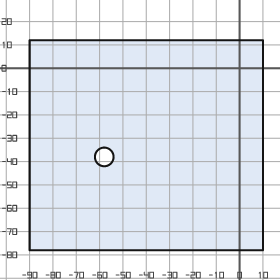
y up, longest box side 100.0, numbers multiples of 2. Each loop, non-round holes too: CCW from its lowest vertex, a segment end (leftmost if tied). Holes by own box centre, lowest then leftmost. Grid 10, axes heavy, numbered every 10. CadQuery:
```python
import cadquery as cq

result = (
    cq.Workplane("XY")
    .moveTo(-90.0, -78.0)
    .lineTo(10.0, -78.0)
    .lineTo(10.0, 12.0)
    .lineTo(-90.0, 12.0)
    .close()
    .moveTo(-58.0, -38.0)
    .circle(4.0)
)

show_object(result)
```